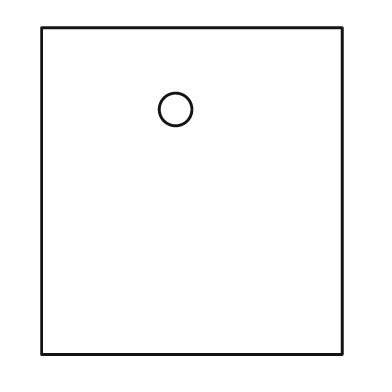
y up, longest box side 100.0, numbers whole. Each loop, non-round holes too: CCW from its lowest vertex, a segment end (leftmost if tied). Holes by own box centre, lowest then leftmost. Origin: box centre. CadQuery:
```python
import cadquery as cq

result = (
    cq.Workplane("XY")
    .moveTo(-46.0, -50.0)
    .lineTo(46.0, -50.0)
    .lineTo(46.0, 50.0)
    .lineTo(-46.0, 50.0)
    .close()
    .moveTo(-5.0, 25.0)
    .circle(5.0)
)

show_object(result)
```